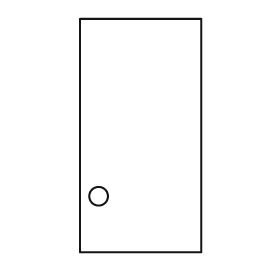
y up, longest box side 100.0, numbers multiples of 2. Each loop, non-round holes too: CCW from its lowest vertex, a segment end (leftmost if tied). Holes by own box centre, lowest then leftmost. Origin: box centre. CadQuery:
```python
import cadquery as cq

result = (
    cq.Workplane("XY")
    .moveTo(-26.0, -50.0)
    .lineTo(26.0, -50.0)
    .lineTo(26.0, 50.0)
    .lineTo(-26.0, 50.0)
    .close()
    .moveTo(-18.0, -26.0)
    .circle(4.0)
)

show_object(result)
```